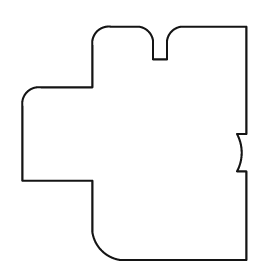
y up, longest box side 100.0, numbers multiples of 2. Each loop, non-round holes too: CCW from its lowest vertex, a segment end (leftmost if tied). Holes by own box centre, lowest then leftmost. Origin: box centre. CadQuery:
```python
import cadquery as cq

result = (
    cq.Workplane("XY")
    .moveTo(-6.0, -50.0)
    .lineTo(48.0, -50.0)
    .lineTo(48.0, -12.0)
    .lineTo(44.0, -12.0)
    .threePointArc((46.0, -4.0), (44.0, 4.0))
    .lineTo(48.0, 4.0)
    .lineTo(48.0, 50.0)
    .lineTo(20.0, 50.0)
    .threePointArc((16.0, 48.0), (14.0, 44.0))
    .lineTo(14.0, 36.0)
    .lineTo(8.0, 36.0)
    .lineTo(8.0, 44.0)
    .threePointArc((6.0, 48.0), (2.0, 50.0))
    .lineTo(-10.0, 50.0)
    .threePointArc((-16.0, 48.0), (-18.0, 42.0))
    .lineTo(-18.0, 24.0)
    .lineTo(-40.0, 24.0)
    .threePointArc((-46.0, 22.0), (-48.0, 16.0))
    .lineTo(-48.0, -16.0)
    .lineTo(-18.0, -16.0)
    .lineTo(-18.0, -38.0)
    .threePointArc((-14.0, -46.0), (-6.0, -50.0))
    .close()
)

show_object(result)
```